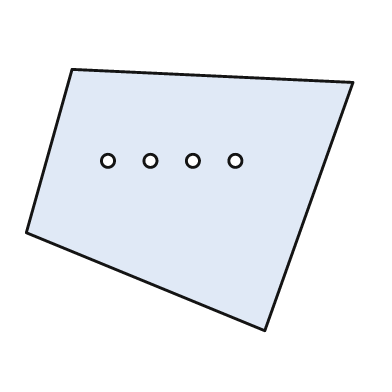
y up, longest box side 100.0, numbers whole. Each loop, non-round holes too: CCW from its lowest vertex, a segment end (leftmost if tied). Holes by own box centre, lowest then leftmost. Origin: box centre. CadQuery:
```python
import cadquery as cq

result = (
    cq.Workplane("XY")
    .moveTo(23.0, -40.0)
    .lineTo(50.0, 36.0)
    .lineTo(-36.0, 40.0)
    .lineTo(-50.0, -10.0)
    .close()
    .moveTo(-25.0, 12.0)
    .circle(2.0)
    .moveTo(-12.0, 12.0)
    .circle(2.0)
    .moveTo(1.0, 12.0)
    .circle(2.0)
    .moveTo(14.0, 12.0)
    .circle(2.0)
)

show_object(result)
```